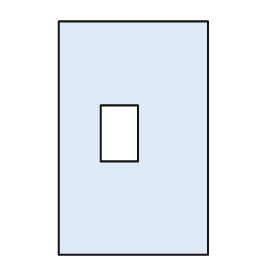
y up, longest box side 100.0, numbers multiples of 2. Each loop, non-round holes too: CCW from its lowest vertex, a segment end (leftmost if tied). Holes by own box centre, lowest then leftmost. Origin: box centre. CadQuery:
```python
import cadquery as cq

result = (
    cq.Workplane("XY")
    .moveTo(-32.0, -50.0)
    .lineTo(32.0, -50.0)
    .lineTo(32.0, 50.0)
    .lineTo(-32.0, 50.0)
    .close()
    .moveTo(-14.0, -10.0)
    .lineTo(2.0, -10.0)
    .lineTo(2.0, 14.0)
    .lineTo(-14.0, 14.0)
    .close()
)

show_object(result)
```